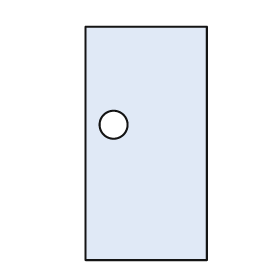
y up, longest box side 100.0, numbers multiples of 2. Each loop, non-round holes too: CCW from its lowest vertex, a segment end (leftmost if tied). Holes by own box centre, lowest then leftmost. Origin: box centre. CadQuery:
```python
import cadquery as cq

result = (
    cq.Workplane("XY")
    .moveTo(-26.0, -50.0)
    .lineTo(26.0, -50.0)
    .lineTo(26.0, 50.0)
    .lineTo(-26.0, 50.0)
    .close()
    .moveTo(-14.0, 8.0)
    .circle(6.0)
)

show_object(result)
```